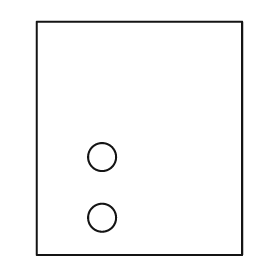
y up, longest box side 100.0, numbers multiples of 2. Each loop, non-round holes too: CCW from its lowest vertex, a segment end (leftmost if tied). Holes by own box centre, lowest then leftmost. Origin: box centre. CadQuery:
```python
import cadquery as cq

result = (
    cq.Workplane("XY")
    .moveTo(-44.0, -50.0)
    .lineTo(44.0, -50.0)
    .lineTo(44.0, 50.0)
    .lineTo(-44.0, 50.0)
    .close()
    .moveTo(-16.0, -34.0)
    .circle(6.0)
    .moveTo(-16.0, -8.0)
    .circle(6.0)
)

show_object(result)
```